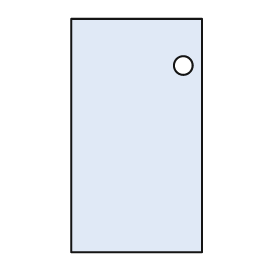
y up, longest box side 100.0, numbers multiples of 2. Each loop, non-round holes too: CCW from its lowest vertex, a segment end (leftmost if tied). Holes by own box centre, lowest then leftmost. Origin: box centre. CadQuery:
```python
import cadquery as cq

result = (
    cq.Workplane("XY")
    .moveTo(-28.0, -50.0)
    .lineTo(28.0, -50.0)
    .lineTo(28.0, 50.0)
    .lineTo(-28.0, 50.0)
    .close()
    .moveTo(20.0, 30.0)
    .circle(4.0)
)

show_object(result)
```